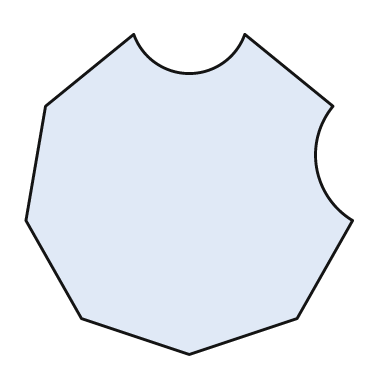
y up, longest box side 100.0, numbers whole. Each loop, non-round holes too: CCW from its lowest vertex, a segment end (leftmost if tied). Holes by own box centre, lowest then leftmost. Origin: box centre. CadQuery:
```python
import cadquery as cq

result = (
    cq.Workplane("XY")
    .moveTo(0.0, -49.0)
    .lineTo(33.0, -38.0)
    .lineTo(50.0, -8.0)
    .threePointArc((39.0, 8.0), (44.0, 27.0))
    .lineTo(17.0, 49.0)
    .threePointArc((0.0, 37.0), (-17.0, 49.0))
    .lineTo(-44.0, 27.0)
    .lineTo(-50.0, -8.0)
    .lineTo(-33.0, -38.0)
    .close()
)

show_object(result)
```